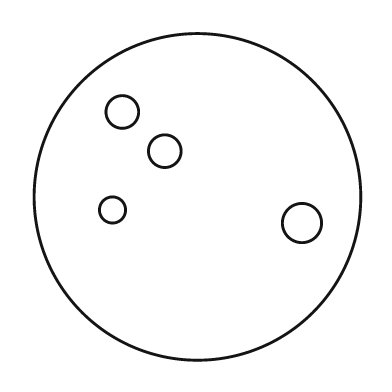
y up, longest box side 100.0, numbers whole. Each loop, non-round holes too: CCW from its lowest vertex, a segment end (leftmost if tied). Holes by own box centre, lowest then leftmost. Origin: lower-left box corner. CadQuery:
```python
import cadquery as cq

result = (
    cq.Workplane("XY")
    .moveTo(50.0, 50.0)
    .circle(50.0)
    .moveTo(82.0, 42.0)
    .circle(6.0)
    .moveTo(24.0, 46.0)
    .circle(4.0)
    .moveTo(40.0, 64.0)
    .circle(5.0)
    .moveTo(27.0, 76.0)
    .circle(5.0)
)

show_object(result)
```